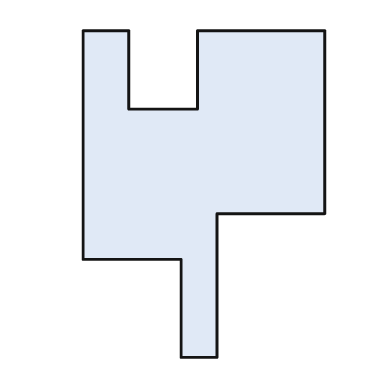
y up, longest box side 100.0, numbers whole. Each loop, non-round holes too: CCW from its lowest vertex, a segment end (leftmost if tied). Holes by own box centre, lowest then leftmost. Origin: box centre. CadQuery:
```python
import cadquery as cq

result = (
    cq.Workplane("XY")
    .moveTo(-7.0, -50.0)
    .lineTo(4.0, -50.0)
    .lineTo(4.0, -6.0)
    .lineTo(37.0, -6.0)
    .lineTo(37.0, 50.0)
    .lineTo(-2.0, 50.0)
    .lineTo(-2.0, 26.0)
    .lineTo(-23.0, 26.0)
    .lineTo(-23.0, 50.0)
    .lineTo(-37.0, 50.0)
    .lineTo(-37.0, -20.0)
    .lineTo(-7.0, -20.0)
    .close()
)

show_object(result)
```